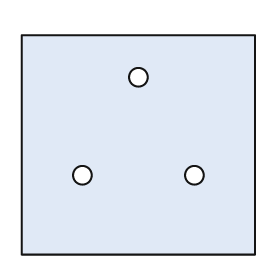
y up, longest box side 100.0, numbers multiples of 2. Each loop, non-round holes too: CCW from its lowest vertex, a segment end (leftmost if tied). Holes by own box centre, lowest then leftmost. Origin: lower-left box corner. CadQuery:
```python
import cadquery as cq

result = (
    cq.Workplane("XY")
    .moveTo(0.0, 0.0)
    .lineTo(100.0, 0.0)
    .lineTo(100.0, 94.0)
    .lineTo(0.0, 94.0)
    .close()
    .moveTo(26.0, 34.0)
    .circle(4.0)
    .moveTo(74.0, 34.0)
    .circle(4.0)
    .moveTo(50.0, 76.0)
    .circle(4.0)
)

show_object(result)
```